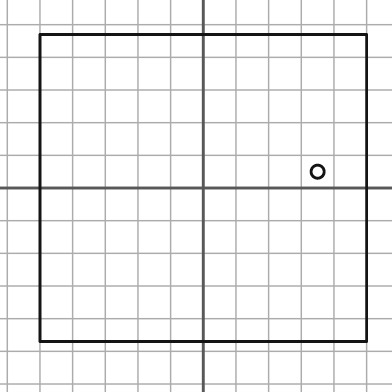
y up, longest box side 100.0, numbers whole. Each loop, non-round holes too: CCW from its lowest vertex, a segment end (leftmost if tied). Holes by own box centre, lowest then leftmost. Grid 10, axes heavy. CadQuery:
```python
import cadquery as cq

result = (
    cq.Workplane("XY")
    .moveTo(-50.0, -47.0)
    .lineTo(50.0, -47.0)
    .lineTo(50.0, 47.0)
    .lineTo(-50.0, 47.0)
    .close()
    .moveTo(35.0, 5.0)
    .circle(2.0)
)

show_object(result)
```